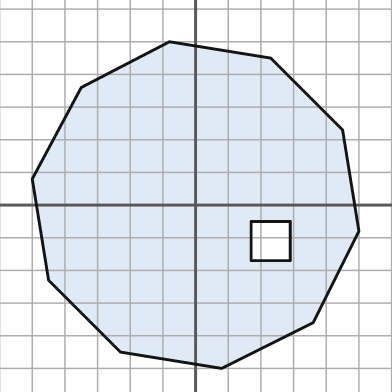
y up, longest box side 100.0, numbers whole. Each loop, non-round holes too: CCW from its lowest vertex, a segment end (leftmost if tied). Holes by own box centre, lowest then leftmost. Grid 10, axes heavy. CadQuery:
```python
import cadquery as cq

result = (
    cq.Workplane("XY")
    .moveTo(8.0, -50.0)
    .lineTo(36.0, -36.0)
    .lineTo(50.0, -8.0)
    .lineTo(45.0, 23.0)
    .lineTo(23.0, 45.0)
    .lineTo(-8.0, 50.0)
    .lineTo(-35.0, 36.0)
    .lineTo(-50.0, 8.0)
    .lineTo(-45.0, -23.0)
    .lineTo(-23.0, -45.0)
    .close()
    .moveTo(17.0, -17.0)
    .lineTo(29.0, -17.0)
    .lineTo(29.0, -5.0)
    .lineTo(17.0, -5.0)
    .close()
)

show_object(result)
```